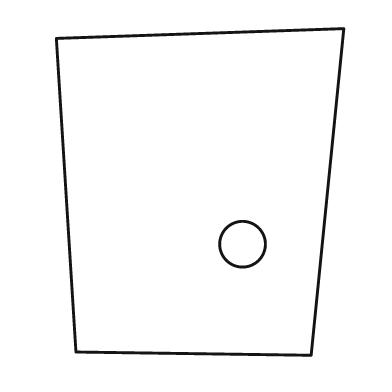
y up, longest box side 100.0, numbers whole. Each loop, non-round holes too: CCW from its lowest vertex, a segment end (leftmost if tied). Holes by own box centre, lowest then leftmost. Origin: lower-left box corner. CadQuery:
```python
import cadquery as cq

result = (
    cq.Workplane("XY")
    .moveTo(78.0, 0.0)
    .lineTo(88.0, 100.0)
    .lineTo(0.0, 97.0)
    .lineTo(6.0, 1.0)
    .close()
    .moveTo(57.0, 34.0)
    .circle(7.0)
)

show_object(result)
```